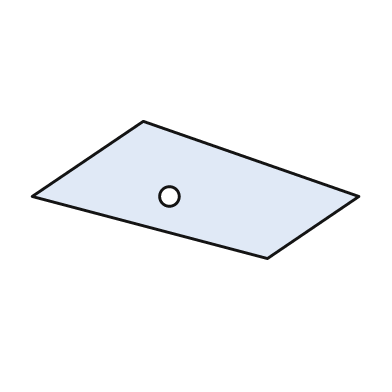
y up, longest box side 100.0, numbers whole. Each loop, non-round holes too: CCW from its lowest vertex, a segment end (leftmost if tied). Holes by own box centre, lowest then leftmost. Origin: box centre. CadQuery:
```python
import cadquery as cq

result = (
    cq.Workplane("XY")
    .moveTo(22.0, -21.0)
    .lineTo(50.0, -2.0)
    .lineTo(-16.0, 21.0)
    .lineTo(-50.0, -2.0)
    .close()
    .moveTo(-8.0, -2.0)
    .circle(3.0)
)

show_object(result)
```